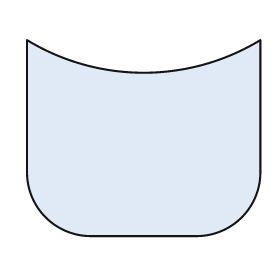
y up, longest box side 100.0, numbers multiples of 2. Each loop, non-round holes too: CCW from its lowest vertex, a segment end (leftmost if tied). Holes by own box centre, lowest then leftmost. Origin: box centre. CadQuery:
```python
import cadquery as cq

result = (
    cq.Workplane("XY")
    .moveTo(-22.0, -42.0)
    .lineTo(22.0, -42.0)
    .threePointArc((42.0, -34.0), (50.0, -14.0))
    .lineTo(50.0, 42.0)
    .threePointArc((0.0, 28.0), (-50.0, 42.0))
    .lineTo(-50.0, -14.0)
    .threePointArc((-42.0, -34.0), (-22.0, -42.0))
    .close()
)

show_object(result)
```